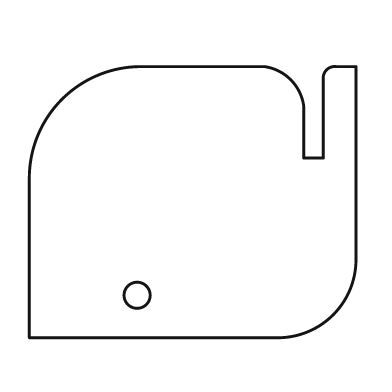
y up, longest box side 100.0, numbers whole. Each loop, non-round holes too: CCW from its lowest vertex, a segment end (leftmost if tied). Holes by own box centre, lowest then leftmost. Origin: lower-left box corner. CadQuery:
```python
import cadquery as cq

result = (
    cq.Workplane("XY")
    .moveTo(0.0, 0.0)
    .lineTo(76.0, 0.0)
    .threePointArc((93.0, 7.0), (100.0, 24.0))
    .lineTo(100.0, 83.0)
    .lineTo(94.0, 83.0)
    .threePointArc((91.0, 82.0), (90.0, 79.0))
    .lineTo(90.0, 55.0)
    .lineTo(84.0, 55.0)
    .lineTo(84.0, 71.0)
    .threePointArc((80.0, 79.0), (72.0, 83.0))
    .lineTo(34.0, 83.0)
    .threePointArc((10.0, 73.0), (0.0, 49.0))
    .close()
    .moveTo(33.0, 13.0)
    .circle(4.0)
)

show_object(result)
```